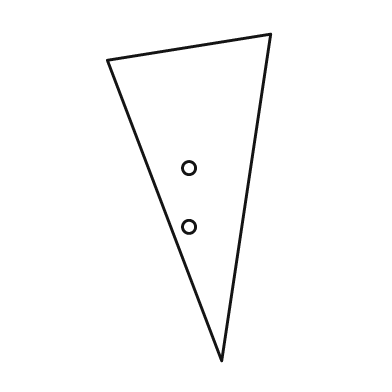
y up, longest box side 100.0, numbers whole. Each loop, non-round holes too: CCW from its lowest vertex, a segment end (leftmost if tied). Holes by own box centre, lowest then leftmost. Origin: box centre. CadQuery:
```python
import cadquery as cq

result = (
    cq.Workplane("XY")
    .moveTo(10.0, -50.0)
    .lineTo(25.0, 50.0)
    .lineTo(-25.0, 42.0)
    .close()
    .moveTo(0.0, -9.0)
    .circle(2.0)
    .moveTo(0.0, 9.0)
    .circle(2.0)
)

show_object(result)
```